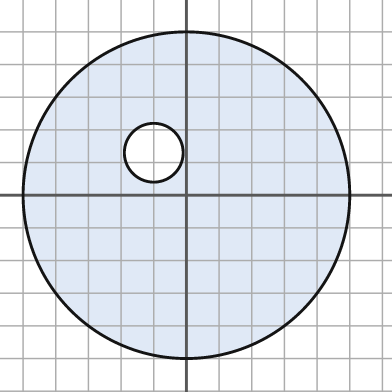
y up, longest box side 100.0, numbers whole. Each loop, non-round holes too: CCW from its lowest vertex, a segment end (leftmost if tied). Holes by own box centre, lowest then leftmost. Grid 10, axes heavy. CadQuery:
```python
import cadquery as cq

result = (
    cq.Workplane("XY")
    .moveTo(0.0, 0.0)
    .circle(50.0)
    .moveTo(-10.0, 13.0)
    .circle(9.0)
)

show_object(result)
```